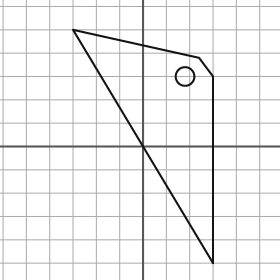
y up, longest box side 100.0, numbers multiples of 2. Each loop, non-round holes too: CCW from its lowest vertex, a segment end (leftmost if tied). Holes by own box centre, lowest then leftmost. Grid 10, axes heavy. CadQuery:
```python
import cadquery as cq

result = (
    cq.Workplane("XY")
    .moveTo(30.0, -50.0)
    .lineTo(30.0, 30.0)
    .lineTo(24.0, 38.0)
    .lineTo(-30.0, 50.0)
    .close()
    .moveTo(18.0, 30.0)
    .circle(4.0)
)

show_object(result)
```